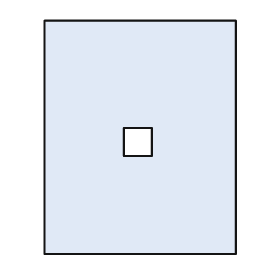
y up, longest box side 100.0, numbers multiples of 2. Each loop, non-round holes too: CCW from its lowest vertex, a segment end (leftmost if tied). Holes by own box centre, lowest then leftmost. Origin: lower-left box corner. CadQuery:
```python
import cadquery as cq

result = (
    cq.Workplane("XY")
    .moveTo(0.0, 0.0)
    .lineTo(82.0, 0.0)
    .lineTo(82.0, 100.0)
    .lineTo(0.0, 100.0)
    .close()
    .moveTo(34.0, 42.0)
    .lineTo(46.0, 42.0)
    .lineTo(46.0, 54.0)
    .lineTo(34.0, 54.0)
    .close()
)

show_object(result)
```